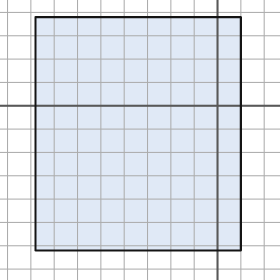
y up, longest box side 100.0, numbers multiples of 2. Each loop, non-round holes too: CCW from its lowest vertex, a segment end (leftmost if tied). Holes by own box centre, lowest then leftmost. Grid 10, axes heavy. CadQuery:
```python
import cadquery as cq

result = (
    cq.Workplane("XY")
    .moveTo(-78.0, -62.0)
    .lineTo(10.0, -62.0)
    .lineTo(10.0, 38.0)
    .lineTo(-78.0, 38.0)
    .close()
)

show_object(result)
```